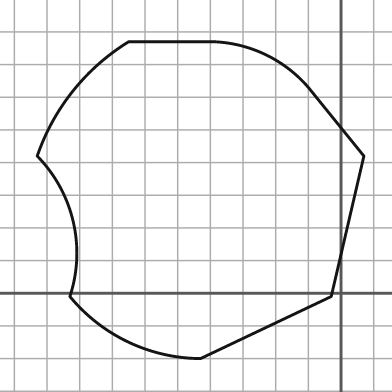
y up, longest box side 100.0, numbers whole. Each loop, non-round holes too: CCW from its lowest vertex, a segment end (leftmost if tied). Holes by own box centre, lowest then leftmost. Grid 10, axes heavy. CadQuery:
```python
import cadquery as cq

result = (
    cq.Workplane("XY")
    .moveTo(-43.0, -20.0)
    .lineTo(-3.0, -1.0)
    .lineTo(7.0, 42.0)
    .lineTo(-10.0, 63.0)
    .threePointArc((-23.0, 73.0), (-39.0, 77.0))
    .lineTo(-65.0, 77.0)
    .threePointArc((-82.0, 62.0), (-93.0, 42.0))
    .threePointArc((-82.0, 22.0), (-83.0, -1.0))
    .threePointArc((-65.0, -15.0), (-43.0, -20.0))
    .close()
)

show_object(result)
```